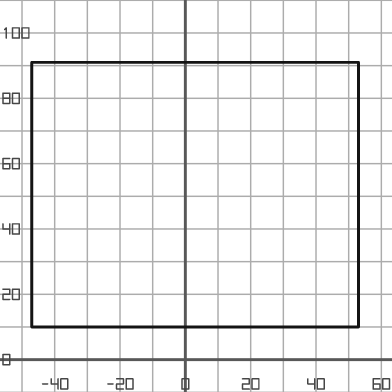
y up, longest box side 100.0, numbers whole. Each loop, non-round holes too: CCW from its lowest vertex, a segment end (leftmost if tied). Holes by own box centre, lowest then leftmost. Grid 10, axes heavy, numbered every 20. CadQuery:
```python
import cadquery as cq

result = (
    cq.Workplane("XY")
    .moveTo(-47.0, 10.0)
    .lineTo(53.0, 10.0)
    .lineTo(53.0, 91.0)
    .lineTo(-47.0, 91.0)
    .close()
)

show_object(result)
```